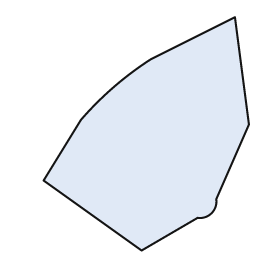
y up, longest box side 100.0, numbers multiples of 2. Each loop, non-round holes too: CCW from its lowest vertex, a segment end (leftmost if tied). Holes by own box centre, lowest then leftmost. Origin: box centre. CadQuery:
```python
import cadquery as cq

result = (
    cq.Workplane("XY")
    .moveTo(-2.0, -50.0)
    .lineTo(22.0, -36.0)
    .threePointArc((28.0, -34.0), (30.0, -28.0))
    .lineTo(44.0, 4.0)
    .lineTo(38.0, 50.0)
    .lineTo(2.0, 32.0)
    .threePointArc((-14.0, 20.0), (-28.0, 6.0))
    .lineTo(-44.0, -20.0)
    .close()
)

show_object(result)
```